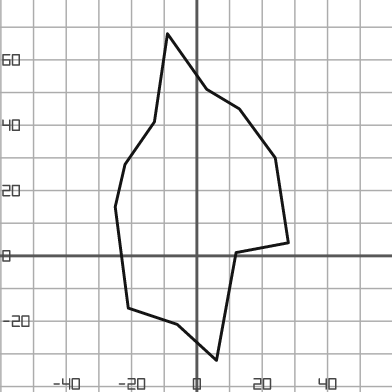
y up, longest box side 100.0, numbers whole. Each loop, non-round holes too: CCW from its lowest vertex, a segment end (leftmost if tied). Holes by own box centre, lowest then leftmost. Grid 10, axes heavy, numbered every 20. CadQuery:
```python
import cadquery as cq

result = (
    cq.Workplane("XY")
    .moveTo(6.0, -32.0)
    .lineTo(12.0, 1.0)
    .lineTo(28.0, 4.0)
    .lineTo(24.0, 30.0)
    .lineTo(13.0, 45.0)
    .lineTo(3.0, 51.0)
    .lineTo(-9.0, 68.0)
    .lineTo(-13.0, 41.0)
    .lineTo(-22.0, 28.0)
    .lineTo(-25.0, 15.0)
    .lineTo(-21.0, -16.0)
    .lineTo(-6.0, -21.0)
    .close()
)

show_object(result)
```